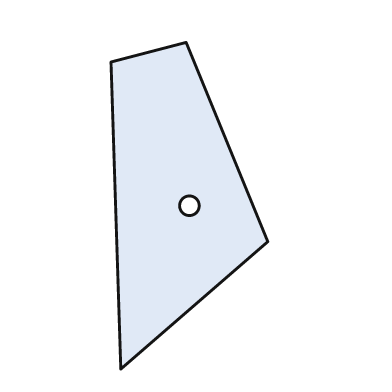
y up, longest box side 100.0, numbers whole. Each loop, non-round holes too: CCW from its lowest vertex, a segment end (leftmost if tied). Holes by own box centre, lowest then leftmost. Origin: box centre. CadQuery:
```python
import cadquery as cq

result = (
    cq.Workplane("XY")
    .moveTo(-21.0, -50.0)
    .lineTo(24.0, -11.0)
    .lineTo(-1.0, 50.0)
    .lineTo(-24.0, 44.0)
    .close()
    .moveTo(0.0, 0.0)
    .circle(3.0)
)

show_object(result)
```